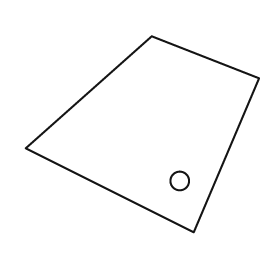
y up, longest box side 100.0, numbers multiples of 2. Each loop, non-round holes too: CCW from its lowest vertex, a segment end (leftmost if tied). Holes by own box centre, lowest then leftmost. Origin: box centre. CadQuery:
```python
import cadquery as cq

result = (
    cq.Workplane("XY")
    .moveTo(22.0, -42.0)
    .lineTo(50.0, 24.0)
    .lineTo(4.0, 42.0)
    .lineTo(-50.0, -6.0)
    .close()
    .moveTo(16.0, -20.0)
    .circle(4.0)
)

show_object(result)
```